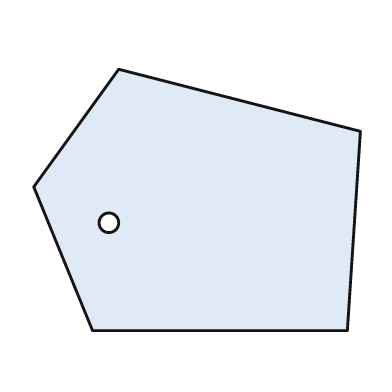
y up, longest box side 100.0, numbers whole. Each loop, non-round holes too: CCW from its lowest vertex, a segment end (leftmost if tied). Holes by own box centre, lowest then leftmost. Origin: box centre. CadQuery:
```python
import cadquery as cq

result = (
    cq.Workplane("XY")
    .moveTo(-32.0, -40.0)
    .lineTo(46.0, -40.0)
    .lineTo(50.0, 21.0)
    .lineTo(-24.0, 40.0)
    .lineTo(-50.0, 4.0)
    .close()
    .moveTo(-27.0, -7.0)
    .circle(3.0)
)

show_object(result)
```